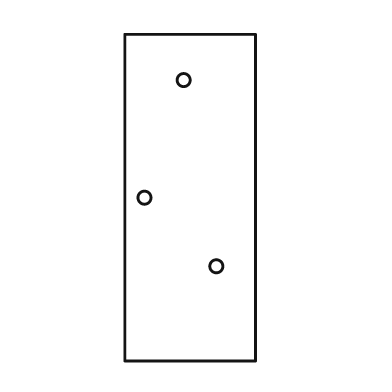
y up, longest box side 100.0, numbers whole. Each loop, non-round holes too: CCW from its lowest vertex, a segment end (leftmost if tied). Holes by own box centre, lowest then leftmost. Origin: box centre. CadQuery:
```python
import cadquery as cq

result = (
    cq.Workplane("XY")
    .moveTo(-20.0, -50.0)
    .lineTo(20.0, -50.0)
    .lineTo(20.0, 50.0)
    .lineTo(-20.0, 50.0)
    .close()
    .moveTo(8.0, -21.0)
    .circle(2.0)
    .moveTo(-14.0, 0.0)
    .circle(2.0)
    .moveTo(-2.0, 36.0)
    .circle(2.0)
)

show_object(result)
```